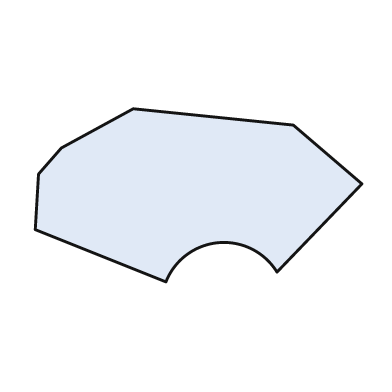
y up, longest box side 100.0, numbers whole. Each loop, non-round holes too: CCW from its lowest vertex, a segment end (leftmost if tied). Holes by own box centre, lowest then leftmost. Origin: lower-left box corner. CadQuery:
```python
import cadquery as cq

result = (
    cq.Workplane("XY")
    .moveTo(40.0, 0.0)
    .threePointArc((56.0, 12.0), (74.0, 3.0))
    .lineTo(100.0, 30.0)
    .lineTo(79.0, 48.0)
    .lineTo(30.0, 53.0)
    .lineTo(8.0, 41.0)
    .lineTo(1.0, 33.0)
    .lineTo(0.0, 16.0)
    .close()
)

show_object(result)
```